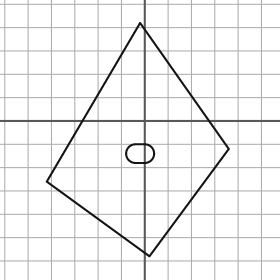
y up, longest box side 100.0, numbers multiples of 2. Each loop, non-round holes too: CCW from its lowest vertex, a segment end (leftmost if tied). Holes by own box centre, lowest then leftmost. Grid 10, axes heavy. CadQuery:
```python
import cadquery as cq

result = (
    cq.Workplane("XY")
    .moveTo(2.0, -58.0)
    .lineTo(36.0, -12.0)
    .lineTo(-2.0, 42.0)
    .lineTo(-42.0, -26.0)
    .close()
    .moveTo(-4.0, -18.0)
    .lineTo(0.0, -18.0)
    .threePointArc((4.0, -14.0), (0.0, -10.0))
    .lineTo(-4.0, -10.0)
    .threePointArc((-8.0, -14.0), (-4.0, -18.0))
    .close()
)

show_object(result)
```